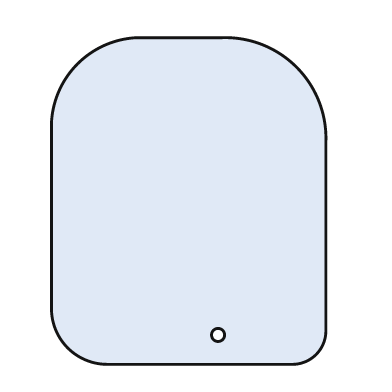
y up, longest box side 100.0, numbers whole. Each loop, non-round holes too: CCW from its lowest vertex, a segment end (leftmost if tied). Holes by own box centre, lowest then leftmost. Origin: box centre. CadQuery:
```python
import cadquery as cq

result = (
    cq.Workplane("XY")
    .moveTo(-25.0, -50.0)
    .lineTo(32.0, -50.0)
    .threePointArc((39.0, -47.0), (42.0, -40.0))
    .lineTo(42.0, 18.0)
    .threePointArc((33.0, 41.0), (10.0, 50.0))
    .lineTo(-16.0, 50.0)
    .threePointArc((-34.0, 42.0), (-42.0, 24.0))
    .lineTo(-42.0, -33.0)
    .threePointArc((-37.0, -45.0), (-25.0, -50.0))
    .close()
    .moveTo(9.0, -41.0)
    .circle(2.0)
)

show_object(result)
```